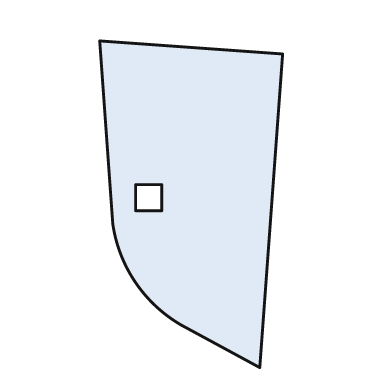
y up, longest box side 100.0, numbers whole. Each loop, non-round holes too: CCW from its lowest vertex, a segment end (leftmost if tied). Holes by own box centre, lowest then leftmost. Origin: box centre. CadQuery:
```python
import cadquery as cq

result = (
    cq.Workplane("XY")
    .moveTo(21.0, -50.0)
    .lineTo(28.0, 46.0)
    .lineTo(-28.0, 50.0)
    .lineTo(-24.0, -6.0)
    .threePointArc((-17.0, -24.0), (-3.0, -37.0))
    .close()
    .moveTo(-17.0, -2.0)
    .lineTo(-9.0, -2.0)
    .lineTo(-9.0, 6.0)
    .lineTo(-17.0, 6.0)
    .close()
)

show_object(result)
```